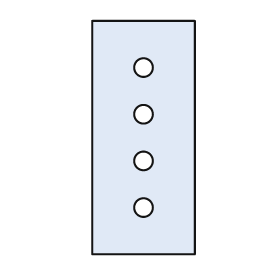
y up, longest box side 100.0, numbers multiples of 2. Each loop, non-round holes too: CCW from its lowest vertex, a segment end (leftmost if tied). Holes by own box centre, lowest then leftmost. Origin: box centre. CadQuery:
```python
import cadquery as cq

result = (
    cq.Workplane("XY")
    .moveTo(-22.0, -50.0)
    .lineTo(22.0, -50.0)
    .lineTo(22.0, 50.0)
    .lineTo(-22.0, 50.0)
    .close()
    .moveTo(0.0, -30.0)
    .circle(4.0)
    .moveTo(0.0, -10.0)
    .circle(4.0)
    .moveTo(0.0, 10.0)
    .circle(4.0)
    .moveTo(0.0, 30.0)
    .circle(4.0)
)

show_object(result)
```